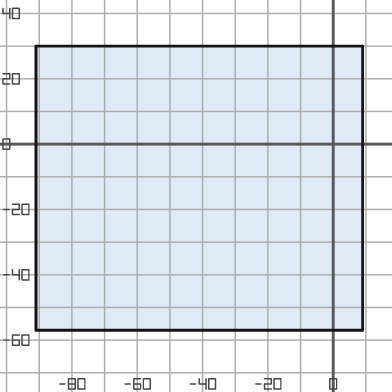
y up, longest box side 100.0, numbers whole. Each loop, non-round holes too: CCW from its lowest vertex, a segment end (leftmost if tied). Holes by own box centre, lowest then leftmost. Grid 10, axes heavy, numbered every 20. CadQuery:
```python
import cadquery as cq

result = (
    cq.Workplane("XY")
    .moveTo(-91.0, -57.0)
    .lineTo(9.0, -57.0)
    .lineTo(9.0, 30.0)
    .lineTo(-91.0, 30.0)
    .close()
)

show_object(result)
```